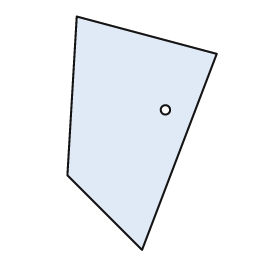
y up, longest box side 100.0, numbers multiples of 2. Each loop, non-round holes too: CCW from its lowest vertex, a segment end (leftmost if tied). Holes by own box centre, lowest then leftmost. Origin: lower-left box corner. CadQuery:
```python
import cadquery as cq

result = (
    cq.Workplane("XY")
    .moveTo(32.0, 0.0)
    .lineTo(64.0, 84.0)
    .lineTo(4.0, 100.0)
    .lineTo(0.0, 32.0)
    .close()
    .moveTo(42.0, 60.0)
    .circle(2.0)
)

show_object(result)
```